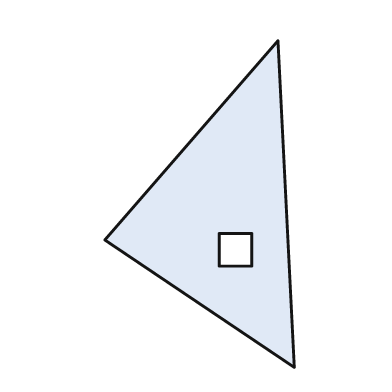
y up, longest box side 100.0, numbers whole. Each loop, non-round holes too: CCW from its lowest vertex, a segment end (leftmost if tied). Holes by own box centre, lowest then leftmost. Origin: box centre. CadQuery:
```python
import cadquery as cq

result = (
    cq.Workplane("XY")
    .moveTo(29.0, -50.0)
    .lineTo(24.0, 50.0)
    .lineTo(-29.0, -11.0)
    .close()
    .moveTo(6.0, -19.0)
    .lineTo(16.0, -19.0)
    .lineTo(16.0, -9.0)
    .lineTo(6.0, -9.0)
    .close()
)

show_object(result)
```